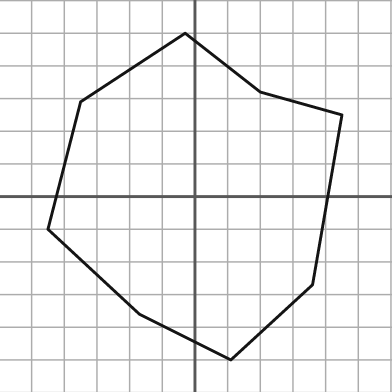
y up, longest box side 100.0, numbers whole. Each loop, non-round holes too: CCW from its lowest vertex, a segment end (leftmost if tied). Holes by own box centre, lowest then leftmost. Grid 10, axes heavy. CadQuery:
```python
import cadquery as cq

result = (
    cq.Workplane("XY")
    .moveTo(11.0, -50.0)
    .lineTo(36.0, -27.0)
    .lineTo(45.0, 25.0)
    .lineTo(20.0, 32.0)
    .lineTo(-3.0, 50.0)
    .lineTo(-35.0, 29.0)
    .lineTo(-45.0, -10.0)
    .lineTo(-17.0, -36.0)
    .close()
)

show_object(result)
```